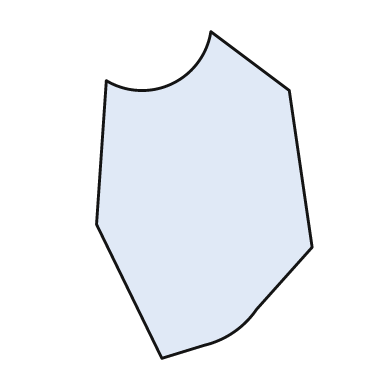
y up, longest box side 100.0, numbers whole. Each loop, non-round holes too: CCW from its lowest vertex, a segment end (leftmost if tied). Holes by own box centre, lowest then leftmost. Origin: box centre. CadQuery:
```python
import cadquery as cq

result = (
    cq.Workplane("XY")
    .moveTo(-13.0, -50.0)
    .lineTo(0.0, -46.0)
    .threePointArc((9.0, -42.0), (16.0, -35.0))
    .lineTo(33.0, -16.0)
    .lineTo(26.0, 32.0)
    .lineTo(2.0, 50.0)
    .threePointArc((-10.0, 34.0), (-30.0, 35.0))
    .lineTo(-33.0, -9.0)
    .close()
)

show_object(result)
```